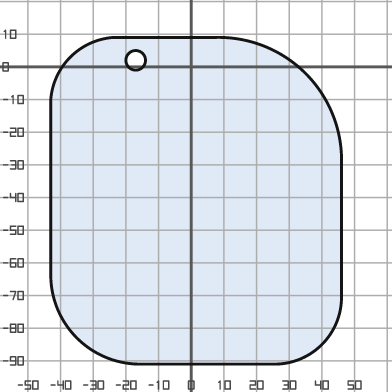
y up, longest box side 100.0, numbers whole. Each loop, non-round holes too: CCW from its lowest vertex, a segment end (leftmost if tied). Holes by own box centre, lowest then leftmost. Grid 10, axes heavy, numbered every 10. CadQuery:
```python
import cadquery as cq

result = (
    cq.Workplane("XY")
    .moveTo(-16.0, -91.0)
    .lineTo(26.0, -91.0)
    .threePointArc((40.0, -85.0), (46.0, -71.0))
    .lineTo(46.0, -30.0)
    .threePointArc((35.0, -2.0), (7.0, 9.0))
    .lineTo(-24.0, 9.0)
    .threePointArc((-37.0, 3.0), (-43.0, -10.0))
    .lineTo(-43.0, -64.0)
    .threePointArc((-35.0, -83.0), (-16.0, -91.0))
    .close()
    .moveTo(-17.0, 2.0)
    .circle(3.0)
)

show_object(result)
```